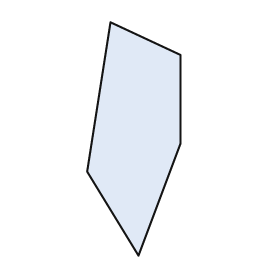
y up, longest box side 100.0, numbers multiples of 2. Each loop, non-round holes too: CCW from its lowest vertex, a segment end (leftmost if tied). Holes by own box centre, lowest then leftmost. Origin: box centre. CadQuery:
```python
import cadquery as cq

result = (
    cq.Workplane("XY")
    .moveTo(2.0, -50.0)
    .lineTo(20.0, -2.0)
    .lineTo(20.0, 36.0)
    .lineTo(-10.0, 50.0)
    .lineTo(-20.0, -14.0)
    .close()
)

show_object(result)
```